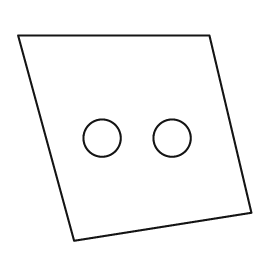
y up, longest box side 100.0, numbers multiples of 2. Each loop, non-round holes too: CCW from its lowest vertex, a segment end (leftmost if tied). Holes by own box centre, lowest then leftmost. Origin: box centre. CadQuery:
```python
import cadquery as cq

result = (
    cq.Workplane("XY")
    .moveTo(-26.0, -44.0)
    .lineTo(50.0, -32.0)
    .lineTo(32.0, 44.0)
    .lineTo(-50.0, 44.0)
    .close()
    .moveTo(-14.0, 0.0)
    .circle(8.0)
    .moveTo(16.0, 0.0)
    .circle(8.0)
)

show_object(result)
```